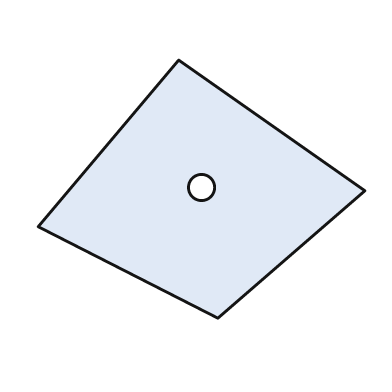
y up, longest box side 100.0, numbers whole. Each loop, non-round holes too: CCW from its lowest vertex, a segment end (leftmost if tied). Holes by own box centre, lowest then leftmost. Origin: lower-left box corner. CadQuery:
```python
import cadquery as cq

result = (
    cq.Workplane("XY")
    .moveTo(55.0, 0.0)
    .lineTo(100.0, 39.0)
    .lineTo(43.0, 79.0)
    .lineTo(0.0, 28.0)
    .close()
    .moveTo(50.0, 40.0)
    .circle(4.0)
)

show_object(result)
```